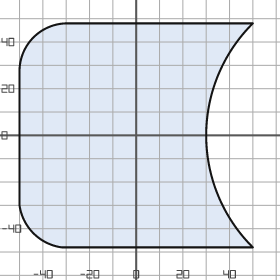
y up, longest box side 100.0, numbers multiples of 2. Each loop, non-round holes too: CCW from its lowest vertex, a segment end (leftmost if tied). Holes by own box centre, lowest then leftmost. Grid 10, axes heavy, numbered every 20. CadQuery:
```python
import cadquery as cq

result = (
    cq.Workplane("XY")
    .moveTo(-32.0, -48.0)
    .lineTo(50.0, -48.0)
    .threePointArc((30.0, 0.0), (50.0, 48.0))
    .lineTo(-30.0, 48.0)
    .threePointArc((-44.0, 42.0), (-50.0, 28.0))
    .lineTo(-50.0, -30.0)
    .threePointArc((-44.0, -42.0), (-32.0, -48.0))
    .close()
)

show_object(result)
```